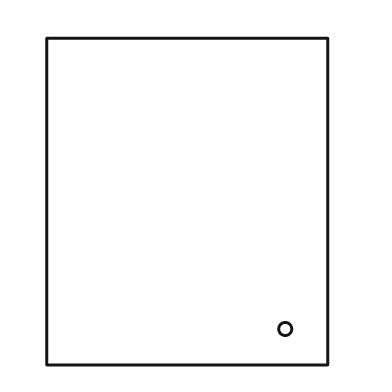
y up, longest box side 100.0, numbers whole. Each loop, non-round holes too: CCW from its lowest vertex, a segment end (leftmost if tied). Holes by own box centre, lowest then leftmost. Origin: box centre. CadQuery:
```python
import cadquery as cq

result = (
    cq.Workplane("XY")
    .moveTo(-43.0, -50.0)
    .lineTo(43.0, -50.0)
    .lineTo(43.0, 50.0)
    .lineTo(-43.0, 50.0)
    .close()
    .moveTo(30.0, -39.0)
    .circle(2.0)
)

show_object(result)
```